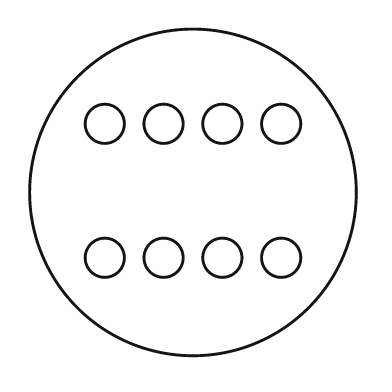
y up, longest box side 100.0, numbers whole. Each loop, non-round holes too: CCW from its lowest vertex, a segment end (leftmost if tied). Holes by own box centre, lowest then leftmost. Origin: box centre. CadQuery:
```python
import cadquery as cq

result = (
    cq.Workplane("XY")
    .moveTo(0.0, 0.0)
    .circle(50.0)
    .moveTo(-27.0, -20.0)
    .circle(6.0)
    .moveTo(-9.0, -20.0)
    .circle(6.0)
    .moveTo(9.0, -20.0)
    .circle(6.0)
    .moveTo(27.0, -20.0)
    .circle(6.0)
    .moveTo(-27.0, 21.0)
    .circle(6.0)
    .moveTo(-9.0, 21.0)
    .circle(6.0)
    .moveTo(9.0, 21.0)
    .circle(6.0)
    .moveTo(27.0, 21.0)
    .circle(6.0)
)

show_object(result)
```